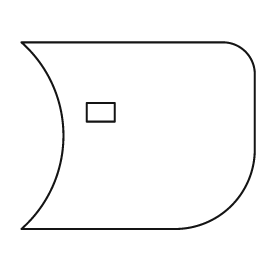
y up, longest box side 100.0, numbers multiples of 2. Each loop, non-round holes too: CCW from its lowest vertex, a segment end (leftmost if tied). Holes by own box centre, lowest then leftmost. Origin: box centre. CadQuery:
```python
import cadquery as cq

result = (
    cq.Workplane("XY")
    .moveTo(-50.0, -40.0)
    .lineTo(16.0, -40.0)
    .threePointArc((40.0, -30.0), (50.0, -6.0))
    .lineTo(50.0, 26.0)
    .threePointArc((46.0, 36.0), (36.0, 40.0))
    .lineTo(-50.0, 40.0)
    .threePointArc((-32.0, 0.0), (-50.0, -40.0))
    .close()
    .moveTo(-22.0, 6.0)
    .lineTo(-10.0, 6.0)
    .lineTo(-10.0, 14.0)
    .lineTo(-22.0, 14.0)
    .close()
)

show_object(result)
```